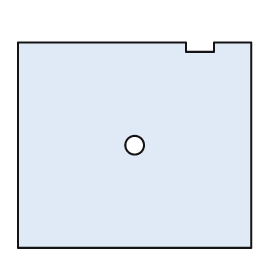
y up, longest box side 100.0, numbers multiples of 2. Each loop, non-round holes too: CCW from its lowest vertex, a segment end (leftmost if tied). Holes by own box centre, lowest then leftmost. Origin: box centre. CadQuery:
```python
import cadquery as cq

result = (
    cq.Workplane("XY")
    .moveTo(-50.0, -44.0)
    .lineTo(50.0, -44.0)
    .lineTo(50.0, 44.0)
    .lineTo(34.0, 44.0)
    .lineTo(34.0, 40.0)
    .lineTo(22.0, 40.0)
    .lineTo(22.0, 44.0)
    .lineTo(-50.0, 44.0)
    .close()
    .moveTo(0.0, 0.0)
    .circle(4.0)
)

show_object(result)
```